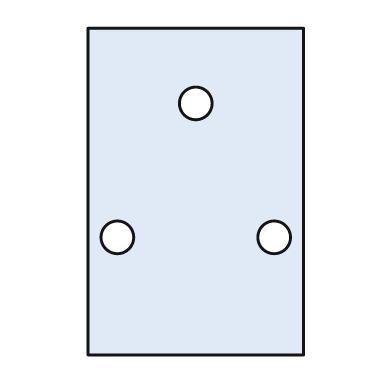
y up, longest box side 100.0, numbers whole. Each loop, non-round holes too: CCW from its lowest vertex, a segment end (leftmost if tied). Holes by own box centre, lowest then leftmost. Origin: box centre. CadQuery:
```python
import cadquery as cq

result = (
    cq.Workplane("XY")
    .moveTo(-33.0, -50.0)
    .lineTo(33.0, -50.0)
    .lineTo(33.0, 50.0)
    .lineTo(-33.0, 50.0)
    .close()
    .moveTo(-24.0, -14.0)
    .circle(5.0)
    .moveTo(24.0, -14.0)
    .circle(5.0)
    .moveTo(0.0, 27.0)
    .circle(5.0)
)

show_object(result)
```